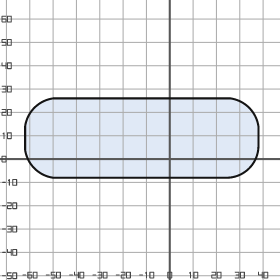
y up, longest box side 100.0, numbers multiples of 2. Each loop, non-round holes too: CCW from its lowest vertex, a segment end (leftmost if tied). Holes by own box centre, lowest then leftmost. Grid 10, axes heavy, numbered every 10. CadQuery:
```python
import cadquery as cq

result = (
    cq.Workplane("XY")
    .moveTo(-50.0, -8.0)
    .lineTo(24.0, -8.0)
    .threePointArc((34.0, -4.0), (38.0, 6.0))
    .lineTo(38.0, 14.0)
    .threePointArc((34.0, 22.0), (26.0, 26.0))
    .lineTo(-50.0, 26.0)
    .threePointArc((-58.0, 22.0), (-62.0, 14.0))
    .lineTo(-62.0, 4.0)
    .threePointArc((-58.0, -4.0), (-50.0, -8.0))
    .close()
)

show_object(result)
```